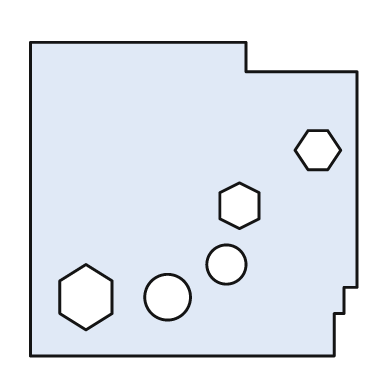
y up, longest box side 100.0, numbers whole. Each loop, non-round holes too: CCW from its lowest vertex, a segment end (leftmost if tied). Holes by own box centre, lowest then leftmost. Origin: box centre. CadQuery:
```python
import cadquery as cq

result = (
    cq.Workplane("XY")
    .moveTo(-50.0, -48.0)
    .lineTo(43.0, -48.0)
    .lineTo(43.0, -35.0)
    .lineTo(46.0, -35.0)
    .lineTo(46.0, -27.0)
    .lineTo(50.0, -27.0)
    .lineTo(50.0, 39.0)
    .lineTo(16.0, 39.0)
    .lineTo(16.0, 48.0)
    .lineTo(-50.0, 48.0)
    .close()
    .moveTo(-33.0, -40.0)
    .lineTo(-25.0, -35.0)
    .lineTo(-25.0, -25.0)
    .lineTo(-33.0, -20.0)
    .lineTo(-41.0, -25.0)
    .lineTo(-41.0, -35.0)
    .close()
    .moveTo(-8.0, -30.0)
    .circle(7.0)
    .moveTo(10.0, -20.0)
    .circle(6.0)
    .moveTo(14.0, -9.0)
    .lineTo(20.0, -6.0)
    .lineTo(20.0, 2.0)
    .lineTo(14.0, 5.0)
    .lineTo(8.0, 2.0)
    .lineTo(8.0, -6.0)
    .close()
    .moveTo(35.0, 9.0)
    .lineTo(41.0, 9.0)
    .lineTo(45.0, 15.0)
    .lineTo(41.0, 21.0)
    .lineTo(35.0, 21.0)
    .lineTo(31.0, 15.0)
    .close()
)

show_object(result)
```